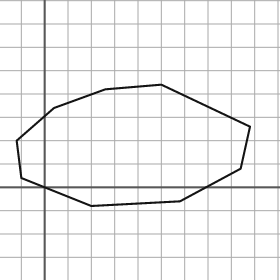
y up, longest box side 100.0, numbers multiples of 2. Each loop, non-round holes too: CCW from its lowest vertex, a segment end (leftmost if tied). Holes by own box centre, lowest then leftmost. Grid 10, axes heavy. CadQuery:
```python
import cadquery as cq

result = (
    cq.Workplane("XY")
    .moveTo(20.0, -8.0)
    .lineTo(58.0, -6.0)
    .lineTo(84.0, 8.0)
    .lineTo(88.0, 26.0)
    .lineTo(50.0, 44.0)
    .lineTo(26.0, 42.0)
    .lineTo(4.0, 34.0)
    .lineTo(-12.0, 20.0)
    .lineTo(-10.0, 4.0)
    .close()
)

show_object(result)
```